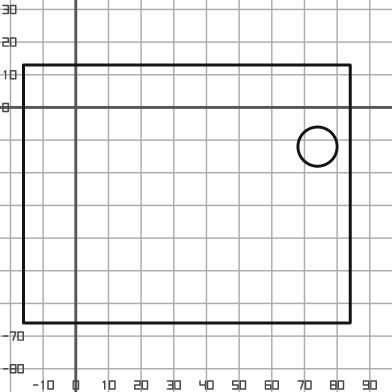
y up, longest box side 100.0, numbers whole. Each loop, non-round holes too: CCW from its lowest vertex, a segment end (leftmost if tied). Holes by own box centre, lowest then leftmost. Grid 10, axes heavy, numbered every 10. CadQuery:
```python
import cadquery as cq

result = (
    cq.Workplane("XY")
    .moveTo(-16.0, -66.0)
    .lineTo(84.0, -66.0)
    .lineTo(84.0, 13.0)
    .lineTo(-16.0, 13.0)
    .close()
    .moveTo(74.0, -12.0)
    .circle(6.0)
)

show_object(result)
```